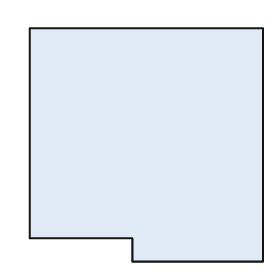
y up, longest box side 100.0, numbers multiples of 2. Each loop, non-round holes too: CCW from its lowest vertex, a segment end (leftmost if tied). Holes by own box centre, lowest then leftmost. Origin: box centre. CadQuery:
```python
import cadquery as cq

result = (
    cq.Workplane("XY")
    .moveTo(-6.0, -50.0)
    .lineTo(50.0, -50.0)
    .lineTo(50.0, 50.0)
    .lineTo(-50.0, 50.0)
    .lineTo(-50.0, -40.0)
    .lineTo(-6.0, -40.0)
    .close()
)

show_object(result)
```